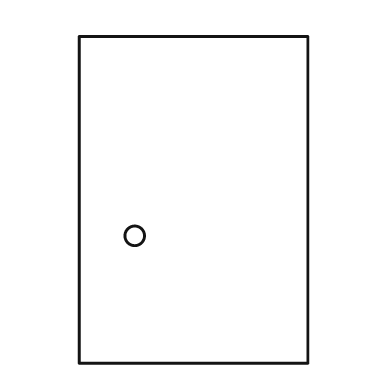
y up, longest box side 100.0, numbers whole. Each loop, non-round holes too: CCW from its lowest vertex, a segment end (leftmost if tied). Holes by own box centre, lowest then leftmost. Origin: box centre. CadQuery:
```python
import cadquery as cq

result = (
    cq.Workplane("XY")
    .moveTo(-35.0, -50.0)
    .lineTo(35.0, -50.0)
    .lineTo(35.0, 50.0)
    .lineTo(-35.0, 50.0)
    .close()
    .moveTo(-18.0, -11.0)
    .circle(3.0)
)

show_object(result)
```